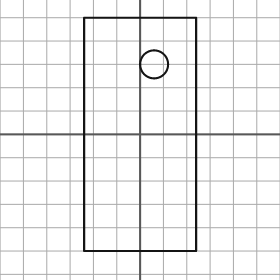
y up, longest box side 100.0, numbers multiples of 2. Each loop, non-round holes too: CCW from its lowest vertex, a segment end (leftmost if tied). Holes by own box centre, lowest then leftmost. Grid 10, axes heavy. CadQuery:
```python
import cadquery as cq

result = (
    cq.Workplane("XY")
    .moveTo(-24.0, -50.0)
    .lineTo(24.0, -50.0)
    .lineTo(24.0, 50.0)
    .lineTo(-24.0, 50.0)
    .close()
    .moveTo(6.0, 30.0)
    .circle(6.0)
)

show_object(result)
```